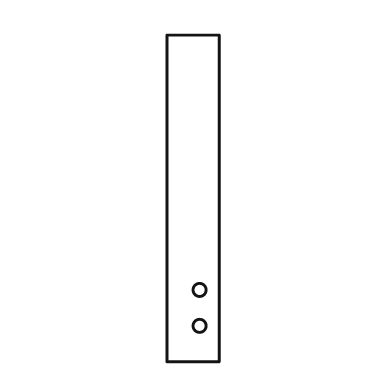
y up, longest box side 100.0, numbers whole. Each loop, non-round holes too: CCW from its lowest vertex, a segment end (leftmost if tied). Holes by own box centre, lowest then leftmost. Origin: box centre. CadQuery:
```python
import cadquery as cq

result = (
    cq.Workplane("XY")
    .moveTo(-8.0, -50.0)
    .lineTo(8.0, -50.0)
    .lineTo(8.0, 50.0)
    .lineTo(-8.0, 50.0)
    .close()
    .moveTo(2.0, -39.0)
    .circle(2.0)
    .moveTo(2.0, -28.0)
    .circle(2.0)
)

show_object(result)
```